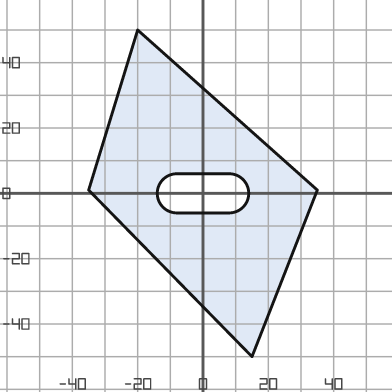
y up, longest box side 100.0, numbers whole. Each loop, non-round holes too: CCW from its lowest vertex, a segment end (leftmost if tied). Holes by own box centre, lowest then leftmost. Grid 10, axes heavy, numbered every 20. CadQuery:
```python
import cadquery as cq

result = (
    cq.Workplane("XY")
    .moveTo(15.0, -50.0)
    .lineTo(35.0, 1.0)
    .lineTo(-20.0, 50.0)
    .lineTo(-35.0, 1.0)
    .close()
    .moveTo(-8.0, -6.0)
    .lineTo(8.0, -6.0)
    .threePointArc((14.0, 0.0), (8.0, 6.0))
    .lineTo(-8.0, 6.0)
    .threePointArc((-14.0, 0.0), (-8.0, -6.0))
    .close()
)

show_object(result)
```